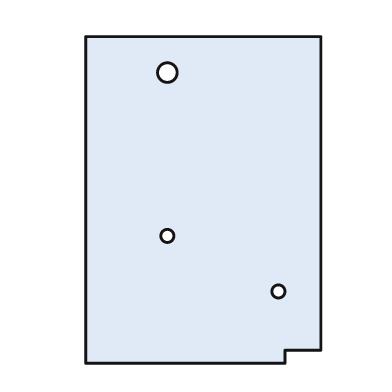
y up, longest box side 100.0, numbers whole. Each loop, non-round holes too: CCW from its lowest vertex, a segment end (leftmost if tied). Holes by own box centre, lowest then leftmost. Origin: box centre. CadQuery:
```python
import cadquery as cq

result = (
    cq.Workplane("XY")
    .moveTo(-36.0, -50.0)
    .lineTo(25.0, -50.0)
    .lineTo(25.0, -46.0)
    .lineTo(36.0, -46.0)
    .lineTo(36.0, 50.0)
    .lineTo(-36.0, 50.0)
    .close()
    .moveTo(23.0, -28.0)
    .circle(2.0)
    .moveTo(-11.0, -11.0)
    .circle(2.0)
    .moveTo(-11.0, 39.0)
    .circle(3.0)
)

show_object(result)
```